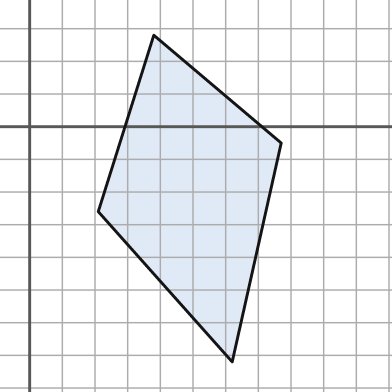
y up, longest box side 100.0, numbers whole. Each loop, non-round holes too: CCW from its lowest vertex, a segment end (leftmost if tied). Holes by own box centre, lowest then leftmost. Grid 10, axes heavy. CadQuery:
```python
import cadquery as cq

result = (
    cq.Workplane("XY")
    .moveTo(62.0, -72.0)
    .lineTo(77.0, -5.0)
    .lineTo(38.0, 28.0)
    .lineTo(21.0, -26.0)
    .close()
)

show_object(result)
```